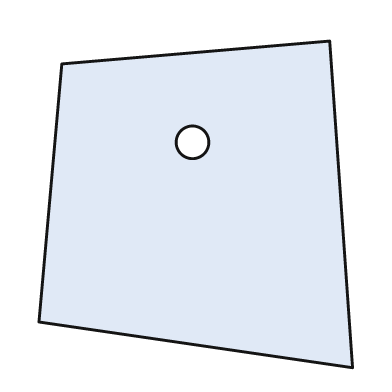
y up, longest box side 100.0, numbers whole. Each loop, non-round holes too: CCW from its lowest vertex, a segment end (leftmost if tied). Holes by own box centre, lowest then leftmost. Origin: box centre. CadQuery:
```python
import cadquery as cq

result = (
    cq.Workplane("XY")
    .moveTo(48.0, -50.0)
    .lineTo(41.0, 50.0)
    .lineTo(-41.0, 43.0)
    .lineTo(-48.0, -36.0)
    .close()
    .moveTo(-1.0, 19.0)
    .circle(5.0)
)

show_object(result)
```